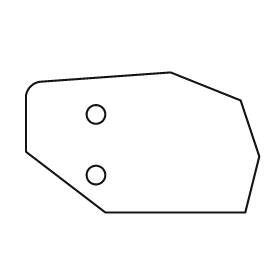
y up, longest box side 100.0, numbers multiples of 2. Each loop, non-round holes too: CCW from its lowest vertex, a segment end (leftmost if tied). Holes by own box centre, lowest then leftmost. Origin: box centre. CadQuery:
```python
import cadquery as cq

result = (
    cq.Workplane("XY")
    .moveTo(-16.0, -30.0)
    .lineTo(44.0, -30.0)
    .lineTo(50.0, -6.0)
    .lineTo(42.0, 18.0)
    .lineTo(12.0, 30.0)
    .lineTo(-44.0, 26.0)
    .threePointArc((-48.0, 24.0), (-50.0, 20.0))
    .lineTo(-50.0, -4.0)
    .close()
    .moveTo(-20.0, -14.0)
    .circle(4.0)
    .moveTo(-20.0, 12.0)
    .circle(4.0)
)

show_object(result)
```